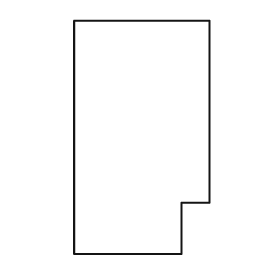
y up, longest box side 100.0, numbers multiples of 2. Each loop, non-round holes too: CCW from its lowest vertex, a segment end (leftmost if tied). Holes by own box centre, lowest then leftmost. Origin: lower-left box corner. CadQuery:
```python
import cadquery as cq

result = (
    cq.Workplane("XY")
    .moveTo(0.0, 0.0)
    .lineTo(46.0, 0.0)
    .lineTo(46.0, 22.0)
    .lineTo(58.0, 22.0)
    .lineTo(58.0, 100.0)
    .lineTo(0.0, 100.0)
    .close()
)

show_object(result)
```